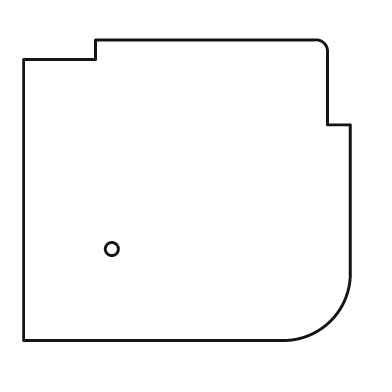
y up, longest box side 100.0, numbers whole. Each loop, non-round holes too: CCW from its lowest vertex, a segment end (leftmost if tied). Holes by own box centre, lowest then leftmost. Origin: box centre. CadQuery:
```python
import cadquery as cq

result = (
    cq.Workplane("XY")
    .moveTo(-50.0, -46.0)
    .lineTo(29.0, -46.0)
    .threePointArc((44.0, -40.0), (50.0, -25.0))
    .lineTo(50.0, 20.0)
    .lineTo(43.0, 20.0)
    .lineTo(43.0, 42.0)
    .threePointArc((42.0, 45.0), (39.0, 46.0))
    .lineTo(-28.0, 46.0)
    .lineTo(-28.0, 40.0)
    .lineTo(-50.0, 40.0)
    .close()
    .moveTo(-23.0, -18.0)
    .circle(2.0)
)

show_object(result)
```